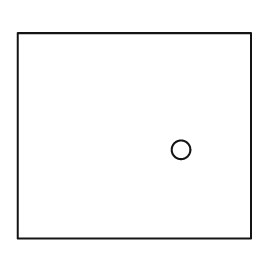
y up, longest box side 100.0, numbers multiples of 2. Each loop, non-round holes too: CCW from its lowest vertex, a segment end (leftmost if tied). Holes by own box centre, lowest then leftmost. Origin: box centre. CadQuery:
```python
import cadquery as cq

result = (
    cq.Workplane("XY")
    .moveTo(-50.0, -44.0)
    .lineTo(50.0, -44.0)
    .lineTo(50.0, 44.0)
    .lineTo(-50.0, 44.0)
    .close()
    .moveTo(20.0, -6.0)
    .circle(4.0)
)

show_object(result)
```